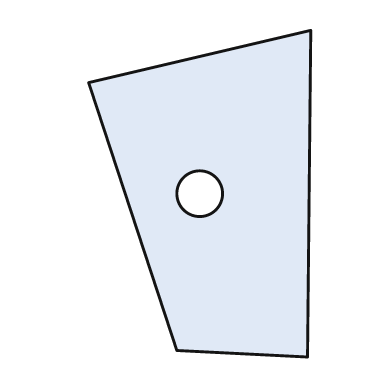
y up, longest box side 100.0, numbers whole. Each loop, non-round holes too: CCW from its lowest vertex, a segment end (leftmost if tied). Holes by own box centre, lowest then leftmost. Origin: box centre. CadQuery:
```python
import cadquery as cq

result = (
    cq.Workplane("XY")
    .moveTo(33.0, -50.0)
    .lineTo(34.0, 50.0)
    .lineTo(-34.0, 34.0)
    .lineTo(-7.0, -48.0)
    .close()
    .moveTo(0.0, 0.0)
    .circle(7.0)
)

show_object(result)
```